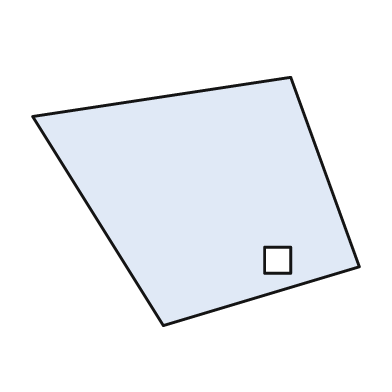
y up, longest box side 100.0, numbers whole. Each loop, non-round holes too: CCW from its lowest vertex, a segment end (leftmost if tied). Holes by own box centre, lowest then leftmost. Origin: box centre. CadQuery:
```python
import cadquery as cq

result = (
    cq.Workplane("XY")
    .moveTo(-10.0, -38.0)
    .lineTo(50.0, -20.0)
    .lineTo(29.0, 38.0)
    .lineTo(-50.0, 26.0)
    .close()
    .moveTo(21.0, -22.0)
    .lineTo(29.0, -22.0)
    .lineTo(29.0, -14.0)
    .lineTo(21.0, -14.0)
    .close()
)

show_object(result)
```